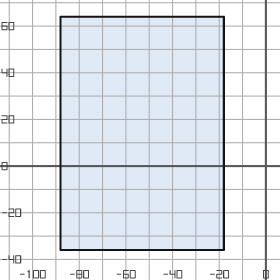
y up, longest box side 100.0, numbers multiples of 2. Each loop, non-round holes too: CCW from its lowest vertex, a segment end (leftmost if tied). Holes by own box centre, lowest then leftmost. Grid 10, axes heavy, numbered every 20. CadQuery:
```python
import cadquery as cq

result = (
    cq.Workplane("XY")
    .moveTo(-88.0, -36.0)
    .lineTo(-18.0, -36.0)
    .lineTo(-18.0, 64.0)
    .lineTo(-88.0, 64.0)
    .close()
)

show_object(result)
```